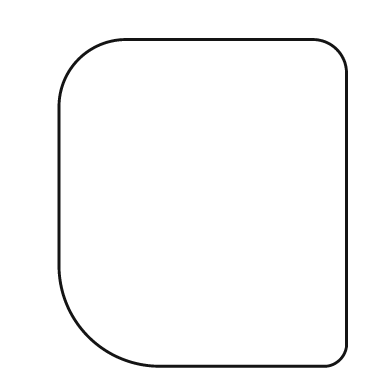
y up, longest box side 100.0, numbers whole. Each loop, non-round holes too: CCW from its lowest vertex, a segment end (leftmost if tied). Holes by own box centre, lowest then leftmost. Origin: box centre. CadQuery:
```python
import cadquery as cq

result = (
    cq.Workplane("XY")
    .moveTo(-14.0, -50.0)
    .lineTo(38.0, -50.0)
    .threePointArc((42.0, -48.0), (44.0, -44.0))
    .lineTo(44.0, 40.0)
    .threePointArc((41.0, 47.0), (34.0, 50.0))
    .lineTo(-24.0, 50.0)
    .threePointArc((-38.0, 44.0), (-44.0, 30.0))
    .lineTo(-44.0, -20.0)
    .threePointArc((-35.0, -41.0), (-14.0, -50.0))
    .close()
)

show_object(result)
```